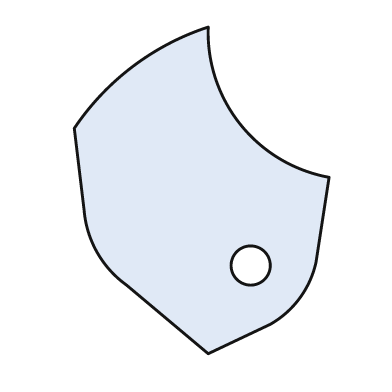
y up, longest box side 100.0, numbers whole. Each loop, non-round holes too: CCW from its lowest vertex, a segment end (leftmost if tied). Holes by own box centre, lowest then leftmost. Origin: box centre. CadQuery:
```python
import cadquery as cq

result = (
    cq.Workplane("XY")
    .moveTo(2.0, -50.0)
    .lineTo(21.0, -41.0)
    .threePointArc((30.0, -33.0), (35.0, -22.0))
    .lineTo(39.0, 4.0)
    .threePointArc((12.0, 20.0), (2.0, 50.0))
    .threePointArc((-21.0, 38.0), (-39.0, 19.0))
    .lineTo(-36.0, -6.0)
    .threePointArc((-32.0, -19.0), (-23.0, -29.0))
    .close()
    .moveTo(15.0, -23.0)
    .circle(6.0)
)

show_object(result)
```